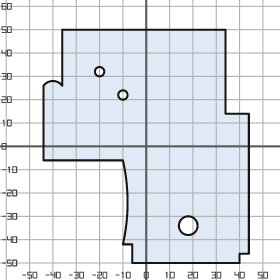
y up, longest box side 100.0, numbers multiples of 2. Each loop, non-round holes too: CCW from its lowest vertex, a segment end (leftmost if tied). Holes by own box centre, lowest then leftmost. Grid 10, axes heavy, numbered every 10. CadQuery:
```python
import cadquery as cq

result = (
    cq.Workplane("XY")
    .moveTo(-6.0, -50.0)
    .lineTo(40.0, -50.0)
    .lineTo(40.0, -46.0)
    .lineTo(44.0, -46.0)
    .lineTo(44.0, 14.0)
    .lineTo(34.0, 14.0)
    .lineTo(34.0, 50.0)
    .lineTo(-36.0, 50.0)
    .lineTo(-36.0, 26.0)
    .threePointArc((-40.0, 28.0), (-44.0, 26.0))
    .lineTo(-44.0, -6.0)
    .lineTo(-10.0, -6.0)
    .threePointArc((-8.0, -24.0), (-10.0, -42.0))
    .lineTo(-6.0, -42.0)
    .close()
    .moveTo(18.0, -34.0)
    .circle(4.0)
    .moveTo(-10.0, 22.0)
    .circle(2.0)
    .moveTo(-20.0, 32.0)
    .circle(2.0)
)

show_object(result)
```